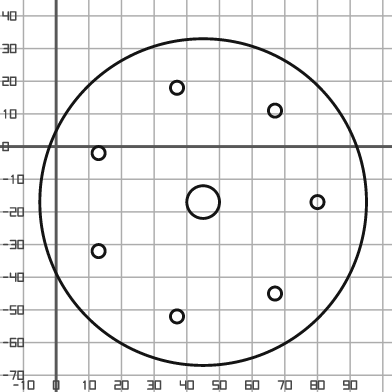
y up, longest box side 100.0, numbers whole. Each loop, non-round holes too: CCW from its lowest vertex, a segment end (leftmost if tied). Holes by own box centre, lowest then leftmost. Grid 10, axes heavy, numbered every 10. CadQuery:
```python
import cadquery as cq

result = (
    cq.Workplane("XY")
    .moveTo(45.0, -17.0)
    .circle(50.0)
    .moveTo(37.0, -52.0)
    .circle(2.0)
    .moveTo(67.0, -45.0)
    .circle(2.0)
    .moveTo(13.0, -32.0)
    .circle(2.0)
    .moveTo(45.0, -17.0)
    .circle(5.0)
    .moveTo(80.0, -17.0)
    .circle(2.0)
    .moveTo(13.0, -2.0)
    .circle(2.0)
    .moveTo(67.0, 11.0)
    .circle(2.0)
    .moveTo(37.0, 18.0)
    .circle(2.0)
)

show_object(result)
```